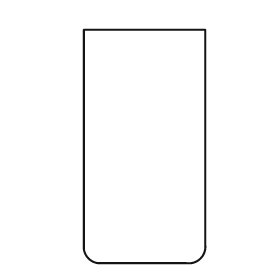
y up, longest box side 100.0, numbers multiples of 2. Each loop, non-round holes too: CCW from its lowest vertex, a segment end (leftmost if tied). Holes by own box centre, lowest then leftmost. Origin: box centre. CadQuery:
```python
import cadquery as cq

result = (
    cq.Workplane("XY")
    .moveTo(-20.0, -50.0)
    .lineTo(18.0, -50.0)
    .threePointArc((24.0, -48.0), (26.0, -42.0))
    .lineTo(26.0, 50.0)
    .lineTo(-26.0, 50.0)
    .lineTo(-26.0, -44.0)
    .threePointArc((-24.0, -48.0), (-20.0, -50.0))
    .close()
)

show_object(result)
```